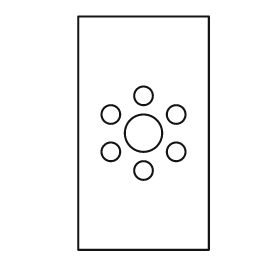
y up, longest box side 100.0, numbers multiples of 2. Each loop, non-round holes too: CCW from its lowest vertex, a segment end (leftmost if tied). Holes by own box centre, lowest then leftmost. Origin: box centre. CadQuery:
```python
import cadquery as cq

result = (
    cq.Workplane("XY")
    .moveTo(-28.0, -50.0)
    .lineTo(28.0, -50.0)
    .lineTo(28.0, 50.0)
    .lineTo(-28.0, 50.0)
    .close()
    .moveTo(0.0, -16.0)
    .circle(4.0)
    .moveTo(-14.0, -8.0)
    .circle(4.0)
    .moveTo(14.0, -8.0)
    .circle(4.0)
    .moveTo(0.0, 0.0)
    .circle(8.0)
    .moveTo(-14.0, 8.0)
    .circle(4.0)
    .moveTo(14.0, 8.0)
    .circle(4.0)
    .moveTo(0.0, 16.0)
    .circle(4.0)
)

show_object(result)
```